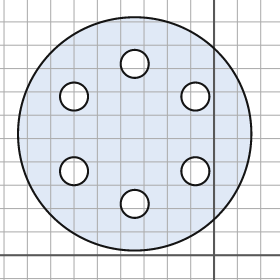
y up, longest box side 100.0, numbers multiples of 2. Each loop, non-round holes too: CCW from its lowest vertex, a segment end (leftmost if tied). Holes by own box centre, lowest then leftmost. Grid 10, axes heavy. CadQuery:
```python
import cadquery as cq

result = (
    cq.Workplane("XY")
    .moveTo(-34.0, 52.0)
    .circle(50.0)
    .moveTo(-34.0, 22.0)
    .circle(6.0)
    .moveTo(-60.0, 36.0)
    .circle(6.0)
    .moveTo(-8.0, 36.0)
    .circle(6.0)
    .moveTo(-60.0, 68.0)
    .circle(6.0)
    .moveTo(-8.0, 68.0)
    .circle(6.0)
    .moveTo(-34.0, 82.0)
    .circle(6.0)
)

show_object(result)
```